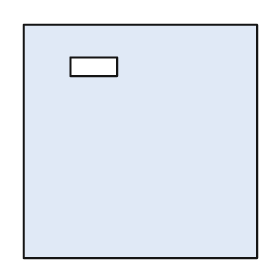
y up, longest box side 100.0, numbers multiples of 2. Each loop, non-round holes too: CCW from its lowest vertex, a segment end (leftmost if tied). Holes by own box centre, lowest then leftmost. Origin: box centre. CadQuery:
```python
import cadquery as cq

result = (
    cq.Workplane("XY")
    .moveTo(-50.0, -50.0)
    .lineTo(50.0, -50.0)
    .lineTo(50.0, 50.0)
    .lineTo(-50.0, 50.0)
    .close()
    .moveTo(-30.0, 28.0)
    .lineTo(-10.0, 28.0)
    .lineTo(-10.0, 36.0)
    .lineTo(-30.0, 36.0)
    .close()
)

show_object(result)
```